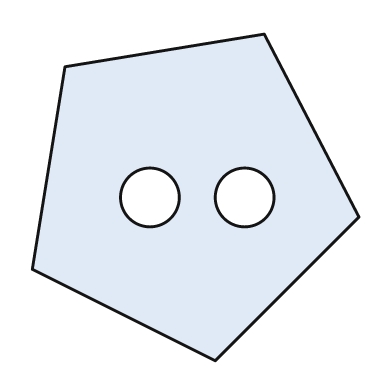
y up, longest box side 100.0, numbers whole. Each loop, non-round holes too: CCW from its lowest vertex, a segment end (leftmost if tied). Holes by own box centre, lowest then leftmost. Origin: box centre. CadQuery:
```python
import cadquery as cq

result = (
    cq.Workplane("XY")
    .moveTo(6.0, -50.0)
    .lineTo(50.0, -6.0)
    .lineTo(21.0, 50.0)
    .lineTo(-40.0, 40.0)
    .lineTo(-50.0, -22.0)
    .close()
    .moveTo(-14.0, 0.0)
    .circle(9.0)
    .moveTo(15.0, 0.0)
    .circle(9.0)
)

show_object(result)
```